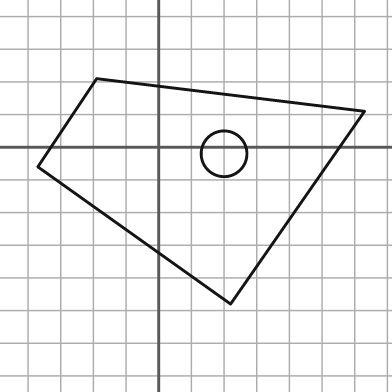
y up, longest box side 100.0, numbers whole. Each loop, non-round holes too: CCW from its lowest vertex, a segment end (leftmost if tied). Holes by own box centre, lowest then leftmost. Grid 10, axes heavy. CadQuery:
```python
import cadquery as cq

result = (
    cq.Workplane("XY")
    .moveTo(22.0, -48.0)
    .lineTo(63.0, 11.0)
    .lineTo(-19.0, 21.0)
    .lineTo(-37.0, -6.0)
    .close()
    .moveTo(20.0, -2.0)
    .circle(7.0)
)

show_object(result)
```